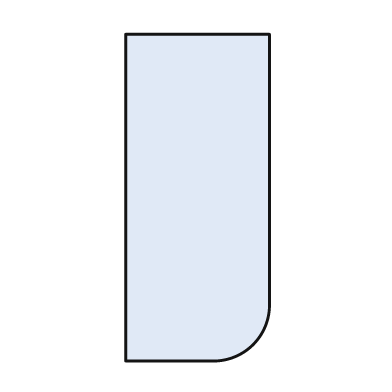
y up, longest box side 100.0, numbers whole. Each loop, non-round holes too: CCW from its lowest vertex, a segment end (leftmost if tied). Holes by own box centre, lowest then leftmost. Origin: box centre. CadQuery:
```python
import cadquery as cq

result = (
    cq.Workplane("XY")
    .moveTo(-22.0, -50.0)
    .lineTo(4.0, -50.0)
    .threePointArc((17.0, -45.0), (22.0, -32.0))
    .lineTo(22.0, 50.0)
    .lineTo(-22.0, 50.0)
    .close()
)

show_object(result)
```